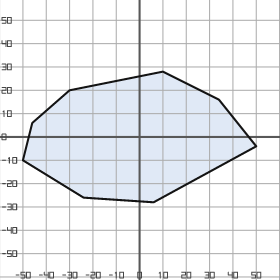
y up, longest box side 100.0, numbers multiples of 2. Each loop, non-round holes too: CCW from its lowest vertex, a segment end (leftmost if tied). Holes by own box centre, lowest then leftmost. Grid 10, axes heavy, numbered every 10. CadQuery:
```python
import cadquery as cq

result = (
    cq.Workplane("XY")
    .moveTo(6.0, -28.0)
    .lineTo(50.0, -4.0)
    .lineTo(34.0, 16.0)
    .lineTo(10.0, 28.0)
    .lineTo(-30.0, 20.0)
    .lineTo(-46.0, 6.0)
    .lineTo(-50.0, -10.0)
    .lineTo(-24.0, -26.0)
    .close()
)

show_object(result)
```